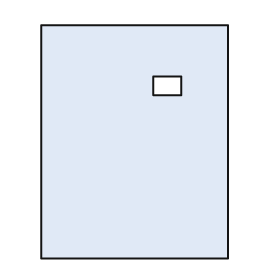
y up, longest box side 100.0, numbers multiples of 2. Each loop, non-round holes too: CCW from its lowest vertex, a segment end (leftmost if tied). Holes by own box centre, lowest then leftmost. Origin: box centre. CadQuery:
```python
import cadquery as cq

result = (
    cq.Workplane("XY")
    .moveTo(-40.0, -50.0)
    .lineTo(40.0, -50.0)
    .lineTo(40.0, 50.0)
    .lineTo(-40.0, 50.0)
    .close()
    .moveTo(8.0, 20.0)
    .lineTo(20.0, 20.0)
    .lineTo(20.0, 28.0)
    .lineTo(8.0, 28.0)
    .close()
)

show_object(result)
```